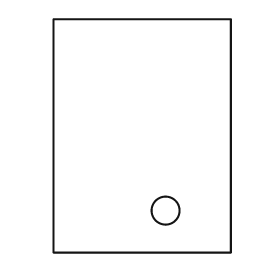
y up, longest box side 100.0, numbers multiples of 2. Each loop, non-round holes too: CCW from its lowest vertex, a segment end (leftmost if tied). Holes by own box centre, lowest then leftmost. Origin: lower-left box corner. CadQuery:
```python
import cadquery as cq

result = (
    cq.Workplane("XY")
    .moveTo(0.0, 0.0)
    .lineTo(76.0, 0.0)
    .lineTo(76.0, 100.0)
    .lineTo(0.0, 100.0)
    .close()
    .moveTo(48.0, 18.0)
    .circle(6.0)
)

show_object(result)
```